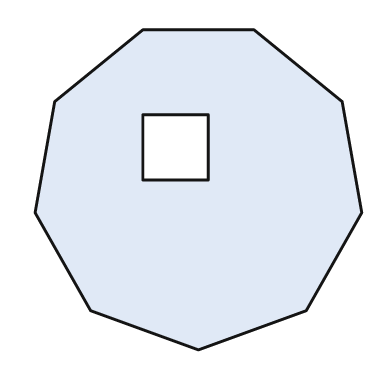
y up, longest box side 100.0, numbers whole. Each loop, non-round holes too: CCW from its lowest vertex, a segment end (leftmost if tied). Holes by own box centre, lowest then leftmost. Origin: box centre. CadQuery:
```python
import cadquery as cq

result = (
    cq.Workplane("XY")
    .moveTo(0.0, -49.0)
    .lineTo(33.0, -37.0)
    .lineTo(50.0, -7.0)
    .lineTo(44.0, 27.0)
    .lineTo(17.0, 49.0)
    .lineTo(-17.0, 49.0)
    .lineTo(-44.0, 27.0)
    .lineTo(-50.0, -7.0)
    .lineTo(-33.0, -37.0)
    .close()
    .moveTo(-17.0, 3.0)
    .lineTo(3.0, 3.0)
    .lineTo(3.0, 23.0)
    .lineTo(-17.0, 23.0)
    .close()
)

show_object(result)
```